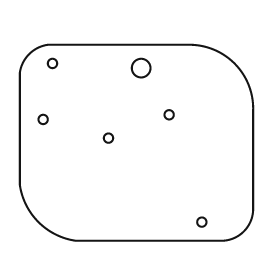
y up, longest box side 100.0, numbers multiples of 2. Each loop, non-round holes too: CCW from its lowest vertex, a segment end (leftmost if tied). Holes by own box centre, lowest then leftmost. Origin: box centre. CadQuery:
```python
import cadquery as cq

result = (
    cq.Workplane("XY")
    .moveTo(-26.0, -42.0)
    .lineTo(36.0, -42.0)
    .threePointArc((46.0, -38.0), (50.0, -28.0))
    .lineTo(50.0, 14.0)
    .threePointArc((42.0, 34.0), (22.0, 42.0))
    .lineTo(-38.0, 42.0)
    .threePointArc((-46.0, 38.0), (-50.0, 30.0))
    .lineTo(-50.0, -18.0)
    .threePointArc((-42.0, -34.0), (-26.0, -42.0))
    .close()
    .moveTo(28.0, -34.0)
    .circle(2.0)
    .moveTo(-12.0, 2.0)
    .circle(2.0)
    .moveTo(-40.0, 10.0)
    .circle(2.0)
    .moveTo(14.0, 12.0)
    .circle(2.0)
    .moveTo(2.0, 32.0)
    .circle(4.0)
    .moveTo(-36.0, 34.0)
    .circle(2.0)
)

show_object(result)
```